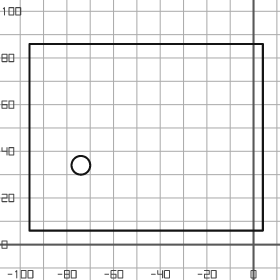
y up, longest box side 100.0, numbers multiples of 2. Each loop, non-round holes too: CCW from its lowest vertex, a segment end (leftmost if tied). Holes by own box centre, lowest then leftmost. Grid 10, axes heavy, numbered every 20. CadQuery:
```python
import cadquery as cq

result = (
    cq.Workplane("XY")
    .moveTo(-96.0, 6.0)
    .lineTo(4.0, 6.0)
    .lineTo(4.0, 86.0)
    .lineTo(-96.0, 86.0)
    .close()
    .moveTo(-74.0, 34.0)
    .circle(4.0)
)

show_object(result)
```